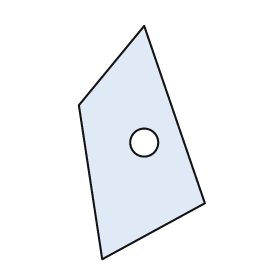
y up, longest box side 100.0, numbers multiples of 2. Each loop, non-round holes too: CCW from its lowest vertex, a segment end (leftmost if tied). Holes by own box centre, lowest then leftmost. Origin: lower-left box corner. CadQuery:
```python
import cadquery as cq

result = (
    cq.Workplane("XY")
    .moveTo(10.0, 0.0)
    .lineTo(54.0, 24.0)
    .lineTo(28.0, 100.0)
    .lineTo(0.0, 66.0)
    .close()
    .moveTo(28.0, 50.0)
    .circle(6.0)
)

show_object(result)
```